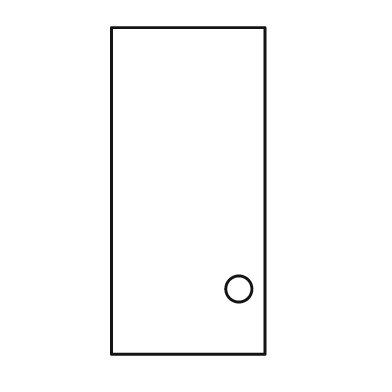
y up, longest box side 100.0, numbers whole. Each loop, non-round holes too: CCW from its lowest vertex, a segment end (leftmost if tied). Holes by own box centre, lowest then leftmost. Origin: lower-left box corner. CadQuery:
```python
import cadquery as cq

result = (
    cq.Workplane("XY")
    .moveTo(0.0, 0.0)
    .lineTo(47.0, 0.0)
    .lineTo(47.0, 100.0)
    .lineTo(0.0, 100.0)
    .close()
    .moveTo(39.0, 20.0)
    .circle(4.0)
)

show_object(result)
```